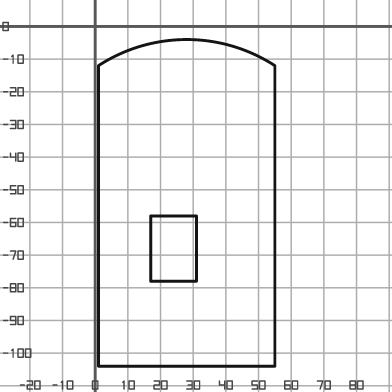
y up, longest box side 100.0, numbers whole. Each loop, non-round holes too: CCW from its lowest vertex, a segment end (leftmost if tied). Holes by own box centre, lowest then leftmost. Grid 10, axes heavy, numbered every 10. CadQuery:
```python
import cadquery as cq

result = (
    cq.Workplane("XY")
    .moveTo(1.0, -104.0)
    .lineTo(55.0, -104.0)
    .lineTo(55.0, -12.0)
    .threePointArc((28.0, -4.0), (1.0, -12.0))
    .close()
    .moveTo(17.0, -78.0)
    .lineTo(31.0, -78.0)
    .lineTo(31.0, -58.0)
    .lineTo(17.0, -58.0)
    .close()
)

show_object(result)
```